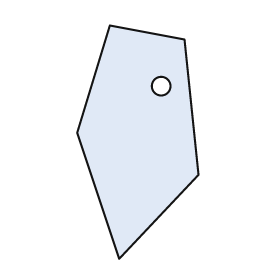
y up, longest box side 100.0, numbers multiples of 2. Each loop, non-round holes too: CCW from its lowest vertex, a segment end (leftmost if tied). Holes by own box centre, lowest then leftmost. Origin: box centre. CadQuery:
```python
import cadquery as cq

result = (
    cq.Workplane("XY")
    .moveTo(-8.0, -50.0)
    .lineTo(26.0, -14.0)
    .lineTo(20.0, 44.0)
    .lineTo(-12.0, 50.0)
    .lineTo(-26.0, 4.0)
    .close()
    .moveTo(10.0, 24.0)
    .circle(4.0)
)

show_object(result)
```